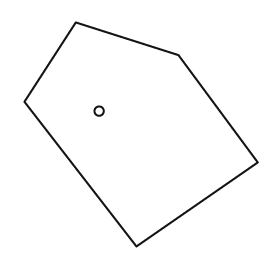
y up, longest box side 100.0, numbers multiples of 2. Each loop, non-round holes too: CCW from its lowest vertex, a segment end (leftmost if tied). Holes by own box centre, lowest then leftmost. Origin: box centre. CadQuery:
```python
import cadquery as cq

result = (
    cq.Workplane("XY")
    .moveTo(-2.0, -48.0)
    .lineTo(50.0, -12.0)
    .lineTo(16.0, 34.0)
    .lineTo(-28.0, 48.0)
    .lineTo(-50.0, 14.0)
    .close()
    .moveTo(-18.0, 10.0)
    .circle(2.0)
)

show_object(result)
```